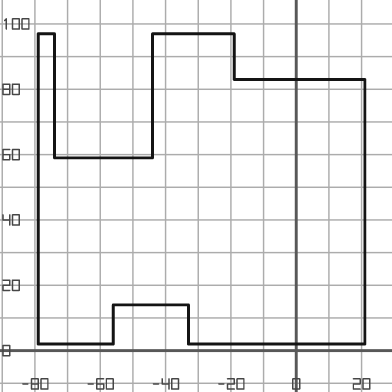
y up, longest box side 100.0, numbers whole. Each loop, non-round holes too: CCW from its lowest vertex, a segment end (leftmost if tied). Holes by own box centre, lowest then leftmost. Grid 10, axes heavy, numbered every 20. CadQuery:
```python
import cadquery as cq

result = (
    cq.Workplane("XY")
    .moveTo(-79.0, 2.0)
    .lineTo(-56.0, 2.0)
    .lineTo(-56.0, 14.0)
    .lineTo(-33.0, 14.0)
    .lineTo(-33.0, 2.0)
    .lineTo(21.0, 2.0)
    .lineTo(21.0, 83.0)
    .lineTo(-19.0, 83.0)
    .lineTo(-19.0, 97.0)
    .lineTo(-44.0, 97.0)
    .lineTo(-44.0, 59.0)
    .lineTo(-74.0, 59.0)
    .lineTo(-74.0, 97.0)
    .lineTo(-79.0, 97.0)
    .close()
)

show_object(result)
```